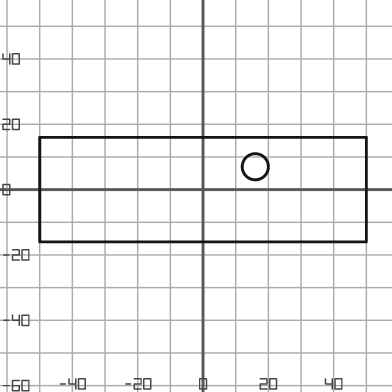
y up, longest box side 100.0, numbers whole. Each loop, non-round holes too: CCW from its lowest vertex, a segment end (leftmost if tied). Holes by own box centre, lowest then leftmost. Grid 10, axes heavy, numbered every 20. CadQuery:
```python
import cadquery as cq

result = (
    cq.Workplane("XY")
    .moveTo(-50.0, -16.0)
    .lineTo(50.0, -16.0)
    .lineTo(50.0, 16.0)
    .lineTo(-50.0, 16.0)
    .close()
    .moveTo(16.0, 7.0)
    .circle(4.0)
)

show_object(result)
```